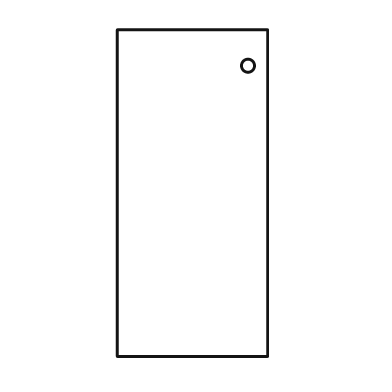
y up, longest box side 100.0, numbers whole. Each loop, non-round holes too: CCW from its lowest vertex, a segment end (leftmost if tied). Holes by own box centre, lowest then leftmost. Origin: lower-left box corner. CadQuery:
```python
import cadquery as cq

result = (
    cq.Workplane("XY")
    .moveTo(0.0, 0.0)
    .lineTo(46.0, 0.0)
    .lineTo(46.0, 100.0)
    .lineTo(0.0, 100.0)
    .close()
    .moveTo(40.0, 89.0)
    .circle(2.0)
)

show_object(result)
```